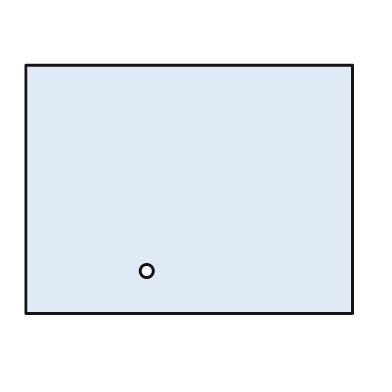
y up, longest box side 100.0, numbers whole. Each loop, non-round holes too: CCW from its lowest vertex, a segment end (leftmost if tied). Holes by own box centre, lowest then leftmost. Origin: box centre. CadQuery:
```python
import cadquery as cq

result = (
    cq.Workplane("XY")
    .moveTo(-50.0, -38.0)
    .lineTo(50.0, -38.0)
    .lineTo(50.0, 38.0)
    .lineTo(-50.0, 38.0)
    .close()
    .moveTo(-13.0, -25.0)
    .circle(2.0)
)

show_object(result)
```